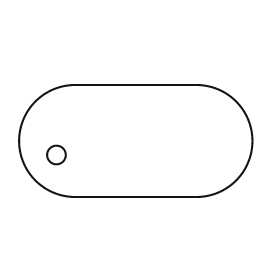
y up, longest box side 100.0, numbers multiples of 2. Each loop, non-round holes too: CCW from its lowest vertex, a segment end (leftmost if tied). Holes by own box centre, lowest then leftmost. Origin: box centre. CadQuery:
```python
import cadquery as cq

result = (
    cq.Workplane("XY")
    .moveTo(-26.0, -24.0)
    .lineTo(26.0, -24.0)
    .threePointArc((50.0, 0.0), (26.0, 24.0))
    .lineTo(-26.0, 24.0)
    .threePointArc((-50.0, 0.0), (-26.0, -24.0))
    .close()
    .moveTo(-34.0, -6.0)
    .circle(4.0)
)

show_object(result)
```